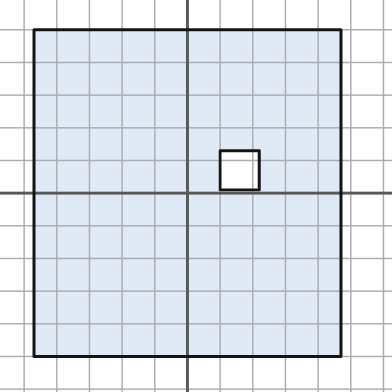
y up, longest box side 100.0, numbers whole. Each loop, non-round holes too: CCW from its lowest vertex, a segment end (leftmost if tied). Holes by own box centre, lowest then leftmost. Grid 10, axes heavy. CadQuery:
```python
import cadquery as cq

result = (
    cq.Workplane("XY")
    .moveTo(-47.0, -50.0)
    .lineTo(47.0, -50.0)
    .lineTo(47.0, 50.0)
    .lineTo(-47.0, 50.0)
    .close()
    .moveTo(10.0, 1.0)
    .lineTo(22.0, 1.0)
    .lineTo(22.0, 13.0)
    .lineTo(10.0, 13.0)
    .close()
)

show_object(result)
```